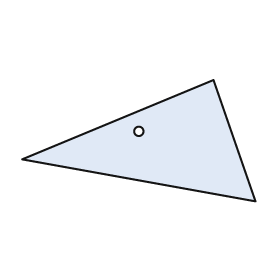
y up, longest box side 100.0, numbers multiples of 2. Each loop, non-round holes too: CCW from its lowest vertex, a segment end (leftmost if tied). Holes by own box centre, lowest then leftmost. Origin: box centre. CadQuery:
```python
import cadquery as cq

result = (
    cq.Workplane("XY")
    .moveTo(50.0, -26.0)
    .lineTo(32.0, 26.0)
    .lineTo(-50.0, -8.0)
    .close()
    .moveTo(0.0, 4.0)
    .circle(2.0)
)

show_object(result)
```